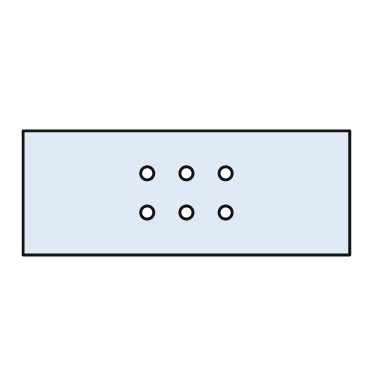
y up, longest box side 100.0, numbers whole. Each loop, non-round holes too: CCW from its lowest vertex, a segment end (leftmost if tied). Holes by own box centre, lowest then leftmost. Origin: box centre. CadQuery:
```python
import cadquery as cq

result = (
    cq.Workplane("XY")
    .moveTo(-50.0, -19.0)
    .lineTo(50.0, -19.0)
    .lineTo(50.0, 19.0)
    .lineTo(-50.0, 19.0)
    .close()
    .moveTo(-12.0, -6.0)
    .circle(2.0)
    .moveTo(0.0, -6.0)
    .circle(2.0)
    .moveTo(12.0, -6.0)
    .circle(2.0)
    .moveTo(-12.0, 6.0)
    .circle(2.0)
    .moveTo(0.0, 6.0)
    .circle(2.0)
    .moveTo(12.0, 6.0)
    .circle(2.0)
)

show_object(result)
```